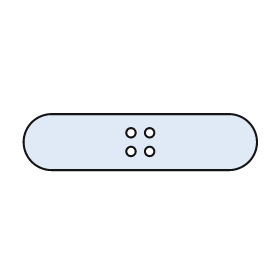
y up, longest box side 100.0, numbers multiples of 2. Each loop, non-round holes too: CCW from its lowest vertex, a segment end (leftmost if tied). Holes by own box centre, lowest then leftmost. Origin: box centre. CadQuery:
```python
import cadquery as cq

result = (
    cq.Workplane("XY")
    .moveTo(-38.0, -12.0)
    .lineTo(38.0, -12.0)
    .threePointArc((50.0, 0.0), (38.0, 12.0))
    .lineTo(-38.0, 12.0)
    .threePointArc((-50.0, 0.0), (-38.0, -12.0))
    .close()
    .moveTo(-4.0, -4.0)
    .circle(2.0)
    .moveTo(4.0, -4.0)
    .circle(2.0)
    .moveTo(-4.0, 4.0)
    .circle(2.0)
    .moveTo(4.0, 4.0)
    .circle(2.0)
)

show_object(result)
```